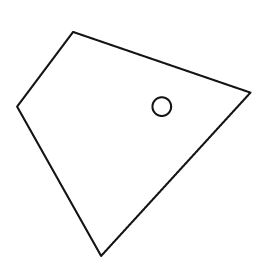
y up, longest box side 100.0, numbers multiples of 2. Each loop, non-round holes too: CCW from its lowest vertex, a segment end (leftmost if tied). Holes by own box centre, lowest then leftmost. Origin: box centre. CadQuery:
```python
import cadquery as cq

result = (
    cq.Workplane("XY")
    .moveTo(-14.0, -48.0)
    .lineTo(50.0, 22.0)
    .lineTo(-26.0, 48.0)
    .lineTo(-50.0, 16.0)
    .close()
    .moveTo(12.0, 16.0)
    .circle(4.0)
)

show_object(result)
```